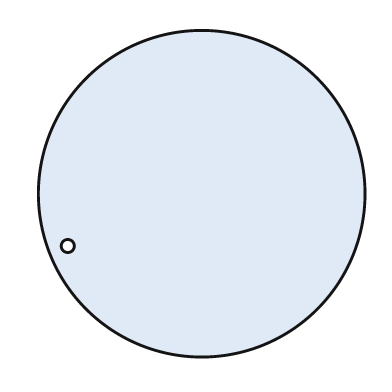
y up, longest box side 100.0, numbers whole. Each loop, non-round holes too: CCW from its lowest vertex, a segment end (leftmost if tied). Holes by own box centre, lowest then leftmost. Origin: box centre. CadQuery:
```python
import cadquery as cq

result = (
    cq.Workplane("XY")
    .moveTo(0.0, 0.0)
    .circle(50.0)
    .moveTo(-41.0, -16.0)
    .circle(2.0)
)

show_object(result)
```